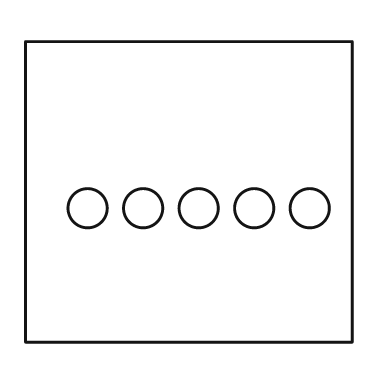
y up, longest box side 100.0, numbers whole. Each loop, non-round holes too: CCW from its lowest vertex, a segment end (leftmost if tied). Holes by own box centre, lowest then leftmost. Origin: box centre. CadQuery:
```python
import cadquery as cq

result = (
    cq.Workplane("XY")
    .moveTo(-50.0, -46.0)
    .lineTo(50.0, -46.0)
    .lineTo(50.0, 46.0)
    .lineTo(-50.0, 46.0)
    .close()
    .moveTo(-31.0, -5.0)
    .circle(6.0)
    .moveTo(-14.0, -5.0)
    .circle(6.0)
    .moveTo(3.0, -5.0)
    .circle(6.0)
    .moveTo(20.0, -5.0)
    .circle(6.0)
    .moveTo(37.0, -5.0)
    .circle(6.0)
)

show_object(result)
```